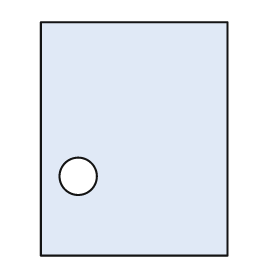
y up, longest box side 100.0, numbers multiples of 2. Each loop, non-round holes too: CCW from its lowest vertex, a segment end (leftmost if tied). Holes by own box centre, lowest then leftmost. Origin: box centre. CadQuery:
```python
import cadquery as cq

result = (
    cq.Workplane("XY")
    .moveTo(-40.0, -50.0)
    .lineTo(40.0, -50.0)
    .lineTo(40.0, 50.0)
    .lineTo(-40.0, 50.0)
    .close()
    .moveTo(-24.0, -16.0)
    .circle(8.0)
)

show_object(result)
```